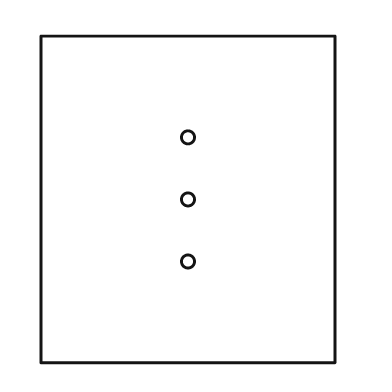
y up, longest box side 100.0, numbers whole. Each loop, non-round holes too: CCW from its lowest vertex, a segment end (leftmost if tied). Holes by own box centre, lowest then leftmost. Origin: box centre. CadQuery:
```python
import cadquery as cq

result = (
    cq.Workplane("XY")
    .moveTo(-45.0, -50.0)
    .lineTo(45.0, -50.0)
    .lineTo(45.0, 50.0)
    .lineTo(-45.0, 50.0)
    .close()
    .moveTo(0.0, -19.0)
    .circle(2.0)
    .moveTo(0.0, 0.0)
    .circle(2.0)
    .moveTo(0.0, 19.0)
    .circle(2.0)
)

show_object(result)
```